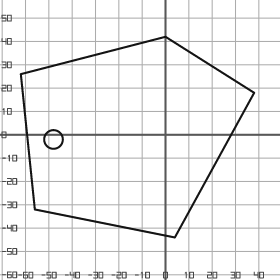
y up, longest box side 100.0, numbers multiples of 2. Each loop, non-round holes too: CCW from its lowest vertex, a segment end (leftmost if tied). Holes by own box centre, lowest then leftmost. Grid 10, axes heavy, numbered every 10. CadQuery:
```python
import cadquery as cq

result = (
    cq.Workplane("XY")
    .moveTo(4.0, -44.0)
    .lineTo(38.0, 18.0)
    .lineTo(0.0, 42.0)
    .lineTo(-62.0, 26.0)
    .lineTo(-56.0, -32.0)
    .close()
    .moveTo(-48.0, -2.0)
    .circle(4.0)
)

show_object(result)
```